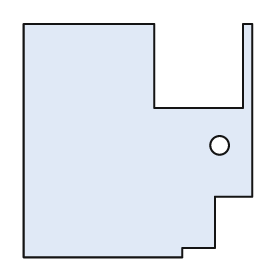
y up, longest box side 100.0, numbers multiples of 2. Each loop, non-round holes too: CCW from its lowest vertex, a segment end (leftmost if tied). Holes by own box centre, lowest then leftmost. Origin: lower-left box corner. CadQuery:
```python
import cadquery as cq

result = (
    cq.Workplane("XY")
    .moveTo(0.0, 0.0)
    .lineTo(68.0, 0.0)
    .lineTo(68.0, 4.0)
    .lineTo(82.0, 4.0)
    .lineTo(82.0, 26.0)
    .lineTo(98.0, 26.0)
    .lineTo(98.0, 100.0)
    .lineTo(94.0, 100.0)
    .lineTo(94.0, 64.0)
    .lineTo(56.0, 64.0)
    .lineTo(56.0, 100.0)
    .lineTo(0.0, 100.0)
    .close()
    .moveTo(84.0, 48.0)
    .circle(4.0)
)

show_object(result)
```